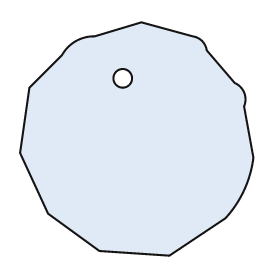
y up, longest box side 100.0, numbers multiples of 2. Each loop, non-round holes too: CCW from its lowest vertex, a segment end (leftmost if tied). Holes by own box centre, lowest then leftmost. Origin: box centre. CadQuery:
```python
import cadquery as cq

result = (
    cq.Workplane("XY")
    .moveTo(14.0, -50.0)
    .lineTo(38.0, -34.0)
    .threePointArc((46.0, -22.0), (50.0, -8.0))
    .lineTo(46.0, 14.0)
    .threePointArc((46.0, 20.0), (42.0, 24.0))
    .lineTo(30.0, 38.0)
    .threePointArc((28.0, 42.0), (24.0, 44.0))
    .lineTo(2.0, 50.0)
    .lineTo(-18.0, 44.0)
    .threePointArc((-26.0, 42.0), (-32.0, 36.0))
    .lineTo(-46.0, 22.0)
    .lineTo(-50.0, -6.0)
    .lineTo(-38.0, -32.0)
    .lineTo(-16.0, -48.0)
    .close()
    .moveTo(-6.0, 26.0)
    .circle(4.0)
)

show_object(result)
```